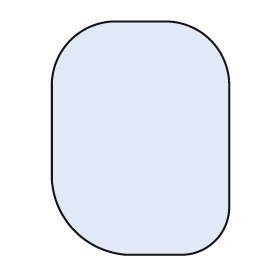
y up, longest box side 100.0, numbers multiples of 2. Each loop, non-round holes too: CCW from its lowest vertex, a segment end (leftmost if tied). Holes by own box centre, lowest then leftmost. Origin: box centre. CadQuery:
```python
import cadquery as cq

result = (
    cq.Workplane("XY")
    .moveTo(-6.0, -50.0)
    .lineTo(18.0, -50.0)
    .threePointArc((32.0, -44.0), (38.0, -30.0))
    .lineTo(38.0, 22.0)
    .threePointArc((30.0, 42.0), (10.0, 50.0))
    .lineTo(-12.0, 50.0)
    .threePointArc((-30.0, 42.0), (-38.0, 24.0))
    .lineTo(-38.0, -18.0)
    .threePointArc((-28.0, -40.0), (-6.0, -50.0))
    .close()
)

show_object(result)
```